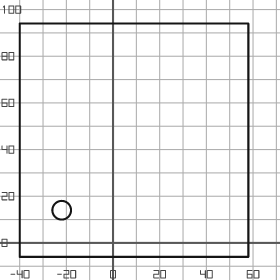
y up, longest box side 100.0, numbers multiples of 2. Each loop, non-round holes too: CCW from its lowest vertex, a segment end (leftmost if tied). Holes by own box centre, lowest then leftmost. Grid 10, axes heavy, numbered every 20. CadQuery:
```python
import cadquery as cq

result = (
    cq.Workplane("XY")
    .moveTo(-40.0, -6.0)
    .lineTo(58.0, -6.0)
    .lineTo(58.0, 94.0)
    .lineTo(-40.0, 94.0)
    .close()
    .moveTo(-22.0, 14.0)
    .circle(4.0)
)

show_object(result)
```